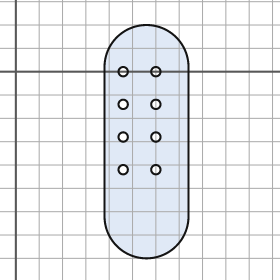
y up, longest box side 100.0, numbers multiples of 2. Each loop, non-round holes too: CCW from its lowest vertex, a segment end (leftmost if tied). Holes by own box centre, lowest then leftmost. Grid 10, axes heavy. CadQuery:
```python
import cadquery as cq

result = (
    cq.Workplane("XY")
    .moveTo(38.0, -62.0)
    .threePointArc((56.0, -80.0), (74.0, -62.0))
    .lineTo(74.0, 2.0)
    .threePointArc((56.0, 20.0), (38.0, 2.0))
    .close()
    .moveTo(46.0, -42.0)
    .circle(2.0)
    .moveTo(60.0, -42.0)
    .circle(2.0)
    .moveTo(46.0, -28.0)
    .circle(2.0)
    .moveTo(60.0, -28.0)
    .circle(2.0)
    .moveTo(46.0, -14.0)
    .circle(2.0)
    .moveTo(60.0, -14.0)
    .circle(2.0)
    .moveTo(46.0, 0.0)
    .circle(2.0)
    .moveTo(60.0, 0.0)
    .circle(2.0)
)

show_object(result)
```